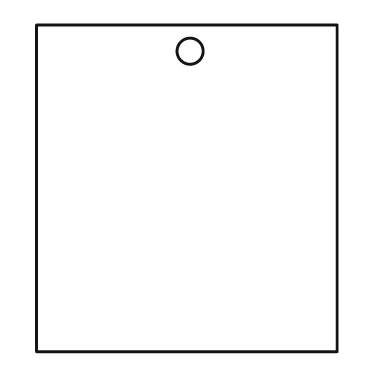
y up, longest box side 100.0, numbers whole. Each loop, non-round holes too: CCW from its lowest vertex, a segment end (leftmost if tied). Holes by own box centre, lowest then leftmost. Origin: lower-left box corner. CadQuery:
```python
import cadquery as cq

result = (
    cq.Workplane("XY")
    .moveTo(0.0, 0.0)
    .lineTo(92.0, 0.0)
    .lineTo(92.0, 100.0)
    .lineTo(0.0, 100.0)
    .close()
    .moveTo(47.0, 92.0)
    .circle(4.0)
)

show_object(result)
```